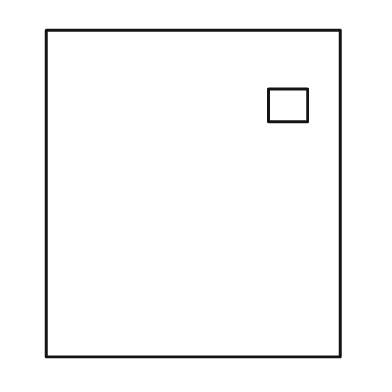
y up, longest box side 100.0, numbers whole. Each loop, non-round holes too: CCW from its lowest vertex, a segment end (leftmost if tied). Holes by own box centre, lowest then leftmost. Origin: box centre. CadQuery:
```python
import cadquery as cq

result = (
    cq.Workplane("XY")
    .moveTo(-45.0, -50.0)
    .lineTo(45.0, -50.0)
    .lineTo(45.0, 50.0)
    .lineTo(-45.0, 50.0)
    .close()
    .moveTo(23.0, 22.0)
    .lineTo(35.0, 22.0)
    .lineTo(35.0, 32.0)
    .lineTo(23.0, 32.0)
    .close()
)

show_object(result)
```